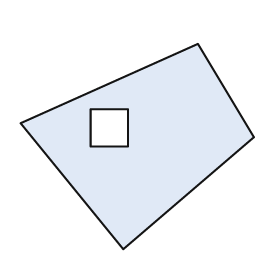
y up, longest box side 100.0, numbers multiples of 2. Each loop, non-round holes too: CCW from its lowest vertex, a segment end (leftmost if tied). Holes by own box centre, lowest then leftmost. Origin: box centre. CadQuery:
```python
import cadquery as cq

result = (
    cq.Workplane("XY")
    .moveTo(-6.0, -44.0)
    .lineTo(50.0, 4.0)
    .lineTo(26.0, 44.0)
    .lineTo(-50.0, 10.0)
    .close()
    .moveTo(-20.0, 0.0)
    .lineTo(-4.0, 0.0)
    .lineTo(-4.0, 16.0)
    .lineTo(-20.0, 16.0)
    .close()
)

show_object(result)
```